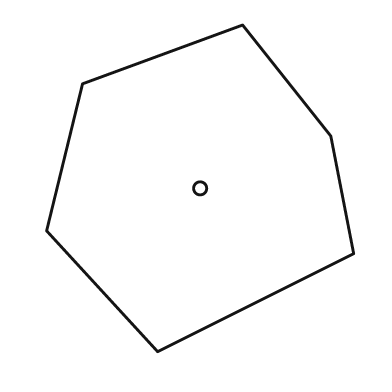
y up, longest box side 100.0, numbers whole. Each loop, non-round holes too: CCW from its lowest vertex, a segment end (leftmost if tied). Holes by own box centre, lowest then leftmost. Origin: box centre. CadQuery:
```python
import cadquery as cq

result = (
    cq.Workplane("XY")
    .moveTo(-13.0, -50.0)
    .lineTo(47.0, -20.0)
    .lineTo(40.0, 16.0)
    .lineTo(13.0, 50.0)
    .lineTo(-36.0, 32.0)
    .lineTo(-47.0, -13.0)
    .close()
    .moveTo(0.0, 0.0)
    .circle(2.0)
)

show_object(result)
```